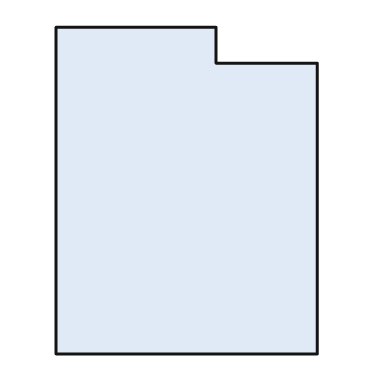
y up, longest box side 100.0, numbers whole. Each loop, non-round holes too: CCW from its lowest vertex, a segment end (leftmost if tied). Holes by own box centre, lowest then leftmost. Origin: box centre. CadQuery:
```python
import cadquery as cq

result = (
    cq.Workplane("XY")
    .moveTo(-40.0, -50.0)
    .lineTo(40.0, -50.0)
    .lineTo(40.0, 39.0)
    .lineTo(9.0, 39.0)
    .lineTo(9.0, 50.0)
    .lineTo(-40.0, 50.0)
    .close()
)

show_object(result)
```